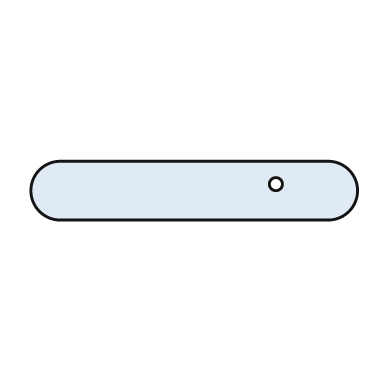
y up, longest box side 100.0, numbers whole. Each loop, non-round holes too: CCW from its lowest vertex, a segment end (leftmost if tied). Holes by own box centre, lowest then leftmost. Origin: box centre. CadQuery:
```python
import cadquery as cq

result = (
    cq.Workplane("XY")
    .moveTo(-41.0, -9.0)
    .lineTo(41.0, -9.0)
    .threePointArc((50.0, 0.0), (41.0, 9.0))
    .lineTo(-41.0, 9.0)
    .threePointArc((-50.0, 0.0), (-41.0, -9.0))
    .close()
    .moveTo(25.0, 2.0)
    .circle(2.0)
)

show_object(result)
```